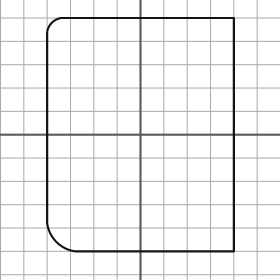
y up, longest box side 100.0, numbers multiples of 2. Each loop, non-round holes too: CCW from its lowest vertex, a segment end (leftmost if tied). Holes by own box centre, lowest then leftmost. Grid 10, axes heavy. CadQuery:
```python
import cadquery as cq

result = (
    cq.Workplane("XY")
    .moveTo(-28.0, -50.0)
    .lineTo(40.0, -50.0)
    .lineTo(40.0, 50.0)
    .lineTo(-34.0, 50.0)
    .threePointArc((-38.0, 48.0), (-40.0, 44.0))
    .lineTo(-40.0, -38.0)
    .threePointArc((-36.0, -46.0), (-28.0, -50.0))
    .close()
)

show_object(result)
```